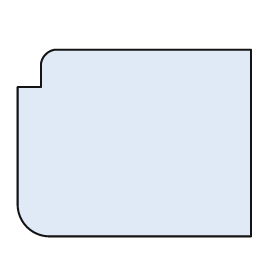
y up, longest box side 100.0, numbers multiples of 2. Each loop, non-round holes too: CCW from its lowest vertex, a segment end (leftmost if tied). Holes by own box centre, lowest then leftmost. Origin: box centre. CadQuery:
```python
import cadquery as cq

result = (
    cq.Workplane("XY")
    .moveTo(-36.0, -40.0)
    .lineTo(50.0, -40.0)
    .lineTo(50.0, 40.0)
    .lineTo(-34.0, 40.0)
    .threePointArc((-38.0, 38.0), (-40.0, 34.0))
    .lineTo(-40.0, 24.0)
    .lineTo(-50.0, 24.0)
    .lineTo(-50.0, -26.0)
    .threePointArc((-46.0, -36.0), (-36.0, -40.0))
    .close()
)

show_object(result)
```